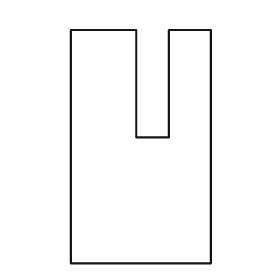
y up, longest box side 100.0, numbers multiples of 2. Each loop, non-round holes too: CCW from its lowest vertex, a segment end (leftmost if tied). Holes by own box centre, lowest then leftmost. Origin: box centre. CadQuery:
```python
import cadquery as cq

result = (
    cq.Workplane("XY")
    .moveTo(-30.0, -50.0)
    .lineTo(30.0, -50.0)
    .lineTo(30.0, 50.0)
    .lineTo(12.0, 50.0)
    .lineTo(12.0, 4.0)
    .lineTo(-2.0, 4.0)
    .lineTo(-2.0, 50.0)
    .lineTo(-30.0, 50.0)
    .close()
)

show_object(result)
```